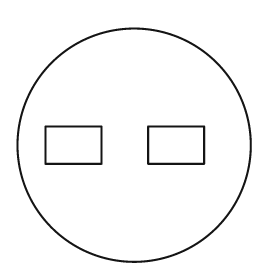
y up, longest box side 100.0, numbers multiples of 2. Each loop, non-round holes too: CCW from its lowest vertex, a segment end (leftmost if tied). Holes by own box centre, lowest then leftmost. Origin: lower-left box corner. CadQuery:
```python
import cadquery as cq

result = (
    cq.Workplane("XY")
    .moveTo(50.0, 50.0)
    .circle(50.0)
    .moveTo(12.0, 42.0)
    .lineTo(36.0, 42.0)
    .lineTo(36.0, 58.0)
    .lineTo(12.0, 58.0)
    .close()
    .moveTo(56.0, 42.0)
    .lineTo(80.0, 42.0)
    .lineTo(80.0, 58.0)
    .lineTo(56.0, 58.0)
    .close()
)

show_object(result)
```